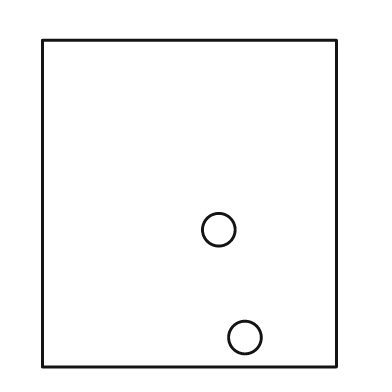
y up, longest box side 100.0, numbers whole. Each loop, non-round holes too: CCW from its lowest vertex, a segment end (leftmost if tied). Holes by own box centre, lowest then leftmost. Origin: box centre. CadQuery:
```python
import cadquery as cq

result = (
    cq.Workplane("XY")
    .moveTo(-45.0, -50.0)
    .lineTo(45.0, -50.0)
    .lineTo(45.0, 50.0)
    .lineTo(-45.0, 50.0)
    .close()
    .moveTo(17.0, -41.0)
    .circle(5.0)
    .moveTo(9.0, -8.0)
    .circle(5.0)
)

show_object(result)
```